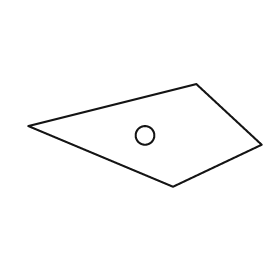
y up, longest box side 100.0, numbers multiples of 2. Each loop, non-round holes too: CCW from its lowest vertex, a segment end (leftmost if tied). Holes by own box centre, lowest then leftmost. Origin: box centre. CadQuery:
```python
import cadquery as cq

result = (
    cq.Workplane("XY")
    .moveTo(12.0, -22.0)
    .lineTo(50.0, -4.0)
    .lineTo(22.0, 22.0)
    .lineTo(-50.0, 4.0)
    .close()
    .moveTo(0.0, 0.0)
    .circle(4.0)
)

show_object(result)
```